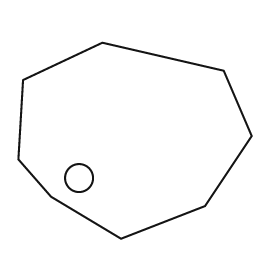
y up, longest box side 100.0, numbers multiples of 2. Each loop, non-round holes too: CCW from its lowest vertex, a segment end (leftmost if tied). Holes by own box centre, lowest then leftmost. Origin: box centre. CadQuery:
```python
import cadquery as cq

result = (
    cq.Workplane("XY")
    .moveTo(-6.0, -42.0)
    .lineTo(30.0, -28.0)
    .lineTo(50.0, 2.0)
    .lineTo(38.0, 30.0)
    .lineTo(-14.0, 42.0)
    .lineTo(-48.0, 26.0)
    .lineTo(-50.0, -8.0)
    .lineTo(-36.0, -24.0)
    .close()
    .moveTo(-24.0, -16.0)
    .circle(6.0)
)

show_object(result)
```